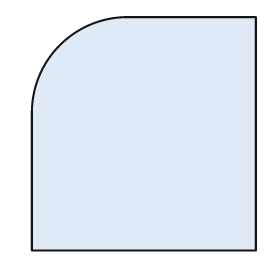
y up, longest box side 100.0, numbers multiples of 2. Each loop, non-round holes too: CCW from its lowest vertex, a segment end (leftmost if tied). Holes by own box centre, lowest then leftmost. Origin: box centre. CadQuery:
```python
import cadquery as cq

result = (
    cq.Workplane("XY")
    .moveTo(-48.0, -50.0)
    .lineTo(48.0, -50.0)
    .lineTo(48.0, 50.0)
    .lineTo(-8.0, 50.0)
    .threePointArc((-36.0, 38.0), (-48.0, 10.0))
    .close()
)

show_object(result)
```